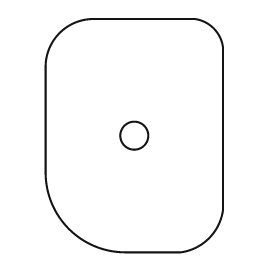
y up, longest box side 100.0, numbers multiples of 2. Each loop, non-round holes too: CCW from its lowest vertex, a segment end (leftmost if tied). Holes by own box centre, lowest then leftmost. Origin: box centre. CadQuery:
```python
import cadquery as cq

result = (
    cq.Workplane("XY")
    .moveTo(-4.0, -50.0)
    .lineTo(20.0, -50.0)
    .threePointArc((32.0, -44.0), (38.0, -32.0))
    .lineTo(38.0, 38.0)
    .threePointArc((34.0, 46.0), (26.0, 50.0))
    .lineTo(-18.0, 50.0)
    .threePointArc((-32.0, 44.0), (-38.0, 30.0))
    .lineTo(-38.0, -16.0)
    .threePointArc((-28.0, -40.0), (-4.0, -50.0))
    .close()
    .moveTo(0.0, 0.0)
    .circle(6.0)
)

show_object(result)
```